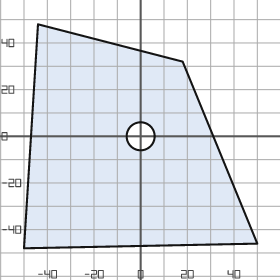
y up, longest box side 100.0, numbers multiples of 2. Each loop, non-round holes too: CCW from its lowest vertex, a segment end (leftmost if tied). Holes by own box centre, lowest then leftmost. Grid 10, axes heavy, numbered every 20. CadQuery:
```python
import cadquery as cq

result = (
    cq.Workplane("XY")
    .moveTo(-50.0, -48.0)
    .lineTo(50.0, -46.0)
    .lineTo(18.0, 32.0)
    .lineTo(-44.0, 48.0)
    .close()
    .moveTo(0.0, 0.0)
    .circle(6.0)
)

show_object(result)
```